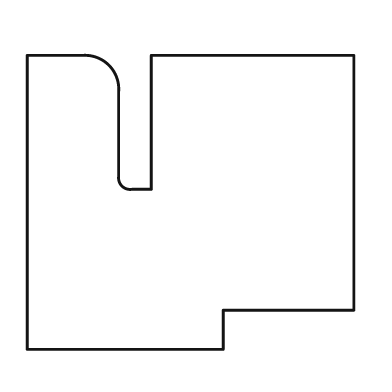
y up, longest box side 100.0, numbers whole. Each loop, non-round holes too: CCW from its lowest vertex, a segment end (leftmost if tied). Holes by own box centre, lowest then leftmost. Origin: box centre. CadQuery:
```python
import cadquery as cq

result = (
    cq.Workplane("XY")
    .moveTo(-50.0, -45.0)
    .lineTo(10.0, -45.0)
    .lineTo(10.0, -33.0)
    .lineTo(50.0, -33.0)
    .lineTo(50.0, 45.0)
    .lineTo(-12.0, 45.0)
    .lineTo(-12.0, 4.0)
    .lineTo(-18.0, 4.0)
    .threePointArc((-21.0, 5.0), (-22.0, 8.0))
    .lineTo(-22.0, 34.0)
    .threePointArc((-25.0, 42.0), (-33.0, 45.0))
    .lineTo(-50.0, 45.0)
    .close()
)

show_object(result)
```